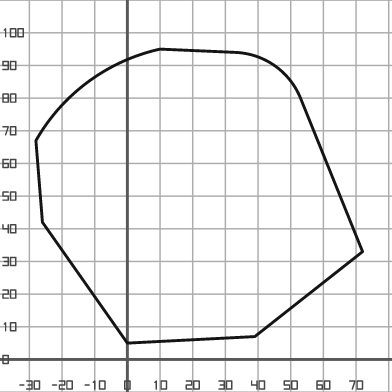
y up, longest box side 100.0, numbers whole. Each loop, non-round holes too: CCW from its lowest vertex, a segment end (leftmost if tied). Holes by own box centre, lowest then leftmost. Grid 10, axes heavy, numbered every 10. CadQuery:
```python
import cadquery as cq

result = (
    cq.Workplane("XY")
    .moveTo(0.0, 5.0)
    .lineTo(39.0, 7.0)
    .lineTo(72.0, 33.0)
    .lineTo(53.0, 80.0)
    .threePointArc((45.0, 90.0), (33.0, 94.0))
    .lineTo(10.0, 95.0)
    .threePointArc((-12.0, 85.0), (-28.0, 67.0))
    .lineTo(-26.0, 42.0)
    .close()
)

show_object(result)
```